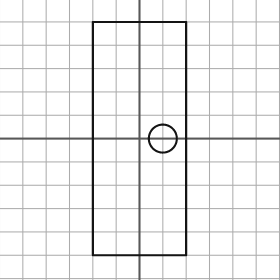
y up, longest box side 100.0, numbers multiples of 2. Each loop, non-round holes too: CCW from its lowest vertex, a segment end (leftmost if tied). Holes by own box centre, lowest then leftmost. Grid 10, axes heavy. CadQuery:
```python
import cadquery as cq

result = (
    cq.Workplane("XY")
    .moveTo(-20.0, -50.0)
    .lineTo(20.0, -50.0)
    .lineTo(20.0, 50.0)
    .lineTo(-20.0, 50.0)
    .close()
    .moveTo(10.0, 0.0)
    .circle(6.0)
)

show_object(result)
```